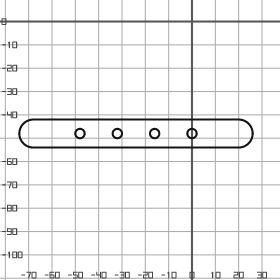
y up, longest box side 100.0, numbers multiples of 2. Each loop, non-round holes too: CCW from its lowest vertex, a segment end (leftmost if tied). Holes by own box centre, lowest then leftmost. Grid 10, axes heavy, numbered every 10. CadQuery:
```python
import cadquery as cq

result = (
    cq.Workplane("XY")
    .moveTo(-68.0, -54.0)
    .lineTo(20.0, -54.0)
    .threePointArc((26.0, -48.0), (20.0, -42.0))
    .lineTo(-68.0, -42.0)
    .threePointArc((-74.0, -48.0), (-68.0, -54.0))
    .close()
    .moveTo(-48.0, -48.0)
    .circle(2.0)
    .moveTo(-32.0, -48.0)
    .circle(2.0)
    .moveTo(-16.0, -48.0)
    .circle(2.0)
    .moveTo(0.0, -48.0)
    .circle(2.0)
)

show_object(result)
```